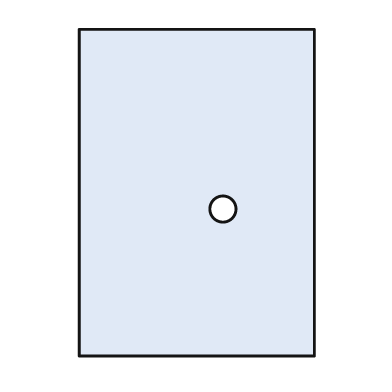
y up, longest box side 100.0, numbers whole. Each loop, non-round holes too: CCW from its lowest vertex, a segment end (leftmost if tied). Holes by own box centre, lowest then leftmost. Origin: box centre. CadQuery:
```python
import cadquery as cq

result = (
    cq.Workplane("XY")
    .moveTo(-36.0, -50.0)
    .lineTo(36.0, -50.0)
    .lineTo(36.0, 50.0)
    .lineTo(-36.0, 50.0)
    .close()
    .moveTo(8.0, -5.0)
    .circle(4.0)
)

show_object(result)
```